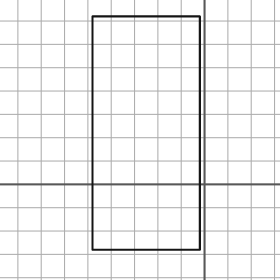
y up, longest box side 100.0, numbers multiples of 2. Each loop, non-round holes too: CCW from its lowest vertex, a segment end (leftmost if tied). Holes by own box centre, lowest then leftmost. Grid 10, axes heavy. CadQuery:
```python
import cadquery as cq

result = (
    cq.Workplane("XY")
    .moveTo(-48.0, -28.0)
    .lineTo(-2.0, -28.0)
    .lineTo(-2.0, 72.0)
    .lineTo(-48.0, 72.0)
    .close()
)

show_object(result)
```